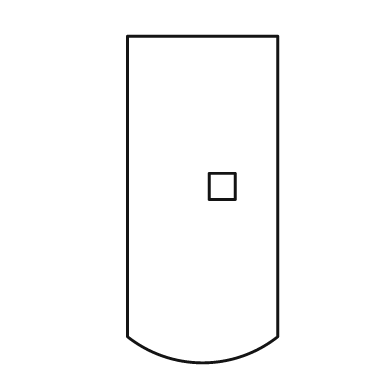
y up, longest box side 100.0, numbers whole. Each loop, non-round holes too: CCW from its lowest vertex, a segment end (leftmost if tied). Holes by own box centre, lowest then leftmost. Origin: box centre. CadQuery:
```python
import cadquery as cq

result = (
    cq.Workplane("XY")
    .moveTo(-23.0, -42.0)
    .threePointArc((0.0, -50.0), (23.0, -42.0))
    .lineTo(23.0, 50.0)
    .lineTo(-23.0, 50.0)
    .close()
    .moveTo(2.0, 0.0)
    .lineTo(10.0, 0.0)
    .lineTo(10.0, 8.0)
    .lineTo(2.0, 8.0)
    .close()
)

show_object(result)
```